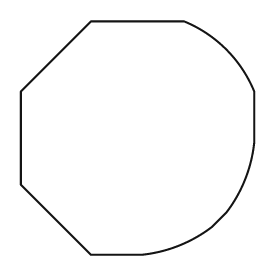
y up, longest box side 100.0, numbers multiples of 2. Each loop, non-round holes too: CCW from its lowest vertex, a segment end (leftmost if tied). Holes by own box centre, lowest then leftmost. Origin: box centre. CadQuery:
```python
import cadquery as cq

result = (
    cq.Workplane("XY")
    .moveTo(-20.0, -50.0)
    .lineTo(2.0, -50.0)
    .threePointArc((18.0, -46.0), (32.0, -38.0))
    .lineTo(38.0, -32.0)
    .threePointArc((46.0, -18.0), (50.0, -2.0))
    .lineTo(50.0, 20.0)
    .threePointArc((38.0, 38.0), (20.0, 50.0))
    .lineTo(-20.0, 50.0)
    .lineTo(-50.0, 20.0)
    .lineTo(-50.0, -20.0)
    .close()
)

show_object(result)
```